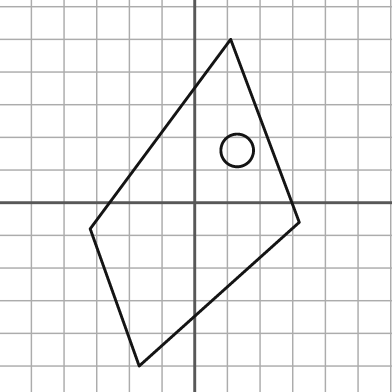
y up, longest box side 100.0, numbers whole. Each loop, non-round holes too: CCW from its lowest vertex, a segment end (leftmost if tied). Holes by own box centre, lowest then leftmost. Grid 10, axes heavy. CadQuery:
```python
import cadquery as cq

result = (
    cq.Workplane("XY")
    .moveTo(-17.0, -50.0)
    .lineTo(32.0, -6.0)
    .lineTo(11.0, 50.0)
    .lineTo(-32.0, -8.0)
    .close()
    .moveTo(13.0, 16.0)
    .circle(5.0)
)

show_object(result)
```